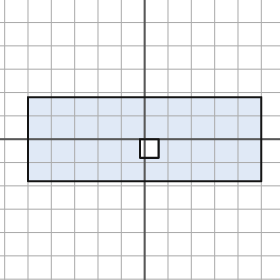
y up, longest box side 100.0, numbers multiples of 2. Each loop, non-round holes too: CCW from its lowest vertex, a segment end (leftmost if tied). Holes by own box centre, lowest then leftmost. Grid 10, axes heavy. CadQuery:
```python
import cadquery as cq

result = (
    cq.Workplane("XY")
    .moveTo(-50.0, -18.0)
    .lineTo(50.0, -18.0)
    .lineTo(50.0, 18.0)
    .lineTo(-50.0, 18.0)
    .close()
    .moveTo(-2.0, -8.0)
    .lineTo(6.0, -8.0)
    .lineTo(6.0, 0.0)
    .lineTo(-2.0, 0.0)
    .close()
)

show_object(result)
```